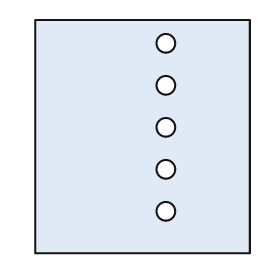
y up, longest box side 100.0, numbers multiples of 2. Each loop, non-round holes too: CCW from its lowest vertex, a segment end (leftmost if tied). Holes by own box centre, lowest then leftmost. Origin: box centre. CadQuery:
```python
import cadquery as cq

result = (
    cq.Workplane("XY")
    .moveTo(-46.0, -50.0)
    .lineTo(46.0, -50.0)
    .lineTo(46.0, 50.0)
    .lineTo(-46.0, 50.0)
    .close()
    .moveTo(10.0, -32.0)
    .circle(4.0)
    .moveTo(10.0, -14.0)
    .circle(4.0)
    .moveTo(10.0, 4.0)
    .circle(4.0)
    .moveTo(10.0, 22.0)
    .circle(4.0)
    .moveTo(10.0, 40.0)
    .circle(4.0)
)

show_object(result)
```